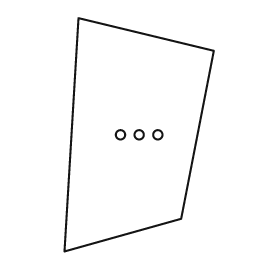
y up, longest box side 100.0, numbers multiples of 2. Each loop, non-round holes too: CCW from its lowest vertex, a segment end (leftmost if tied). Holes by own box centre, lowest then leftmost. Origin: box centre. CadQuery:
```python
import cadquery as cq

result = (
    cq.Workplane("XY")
    .moveTo(-32.0, -50.0)
    .lineTo(18.0, -36.0)
    .lineTo(32.0, 36.0)
    .lineTo(-26.0, 50.0)
    .close()
    .moveTo(-8.0, 0.0)
    .circle(2.0)
    .moveTo(0.0, 0.0)
    .circle(2.0)
    .moveTo(8.0, 0.0)
    .circle(2.0)
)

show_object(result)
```